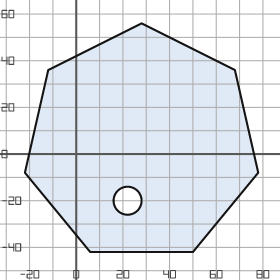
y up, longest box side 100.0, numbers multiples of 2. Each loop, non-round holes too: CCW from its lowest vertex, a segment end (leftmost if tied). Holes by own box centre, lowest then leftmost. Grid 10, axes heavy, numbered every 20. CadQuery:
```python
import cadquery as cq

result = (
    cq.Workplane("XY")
    .moveTo(6.0, -42.0)
    .lineTo(50.0, -42.0)
    .lineTo(78.0, -8.0)
    .lineTo(68.0, 36.0)
    .lineTo(28.0, 56.0)
    .lineTo(-12.0, 36.0)
    .lineTo(-22.0, -8.0)
    .close()
    .moveTo(22.0, -20.0)
    .circle(6.0)
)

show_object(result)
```